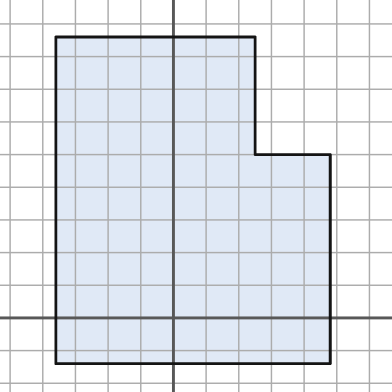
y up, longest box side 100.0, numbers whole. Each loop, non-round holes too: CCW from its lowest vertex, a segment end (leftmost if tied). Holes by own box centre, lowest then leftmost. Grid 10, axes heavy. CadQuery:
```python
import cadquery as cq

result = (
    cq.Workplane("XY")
    .moveTo(-36.0, -14.0)
    .lineTo(48.0, -14.0)
    .lineTo(48.0, 50.0)
    .lineTo(25.0, 50.0)
    .lineTo(25.0, 86.0)
    .lineTo(-36.0, 86.0)
    .close()
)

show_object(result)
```